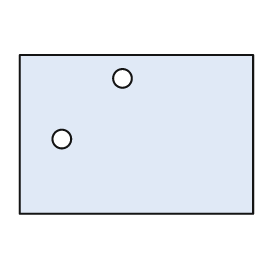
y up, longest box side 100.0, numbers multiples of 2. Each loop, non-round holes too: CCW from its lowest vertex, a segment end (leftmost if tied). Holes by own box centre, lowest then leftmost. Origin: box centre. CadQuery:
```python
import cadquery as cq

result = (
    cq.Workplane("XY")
    .moveTo(-50.0, -34.0)
    .lineTo(50.0, -34.0)
    .lineTo(50.0, 34.0)
    .lineTo(-50.0, 34.0)
    .close()
    .moveTo(-32.0, -2.0)
    .circle(4.0)
    .moveTo(-6.0, 24.0)
    .circle(4.0)
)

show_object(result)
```